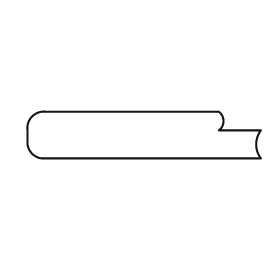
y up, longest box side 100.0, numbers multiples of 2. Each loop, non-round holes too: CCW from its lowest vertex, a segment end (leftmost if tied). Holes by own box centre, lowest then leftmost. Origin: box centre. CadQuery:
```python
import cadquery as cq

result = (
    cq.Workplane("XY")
    .moveTo(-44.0, -10.0)
    .lineTo(50.0, -10.0)
    .threePointArc((48.0, -4.0), (50.0, 2.0))
    .lineTo(32.0, 2.0)
    .threePointArc((34.0, 6.0), (32.0, 10.0))
    .lineTo(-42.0, 10.0)
    .threePointArc((-48.0, 8.0), (-50.0, 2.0))
    .lineTo(-50.0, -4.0)
    .threePointArc((-48.0, -8.0), (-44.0, -10.0))
    .close()
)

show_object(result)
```